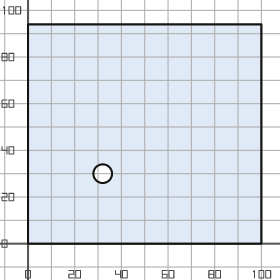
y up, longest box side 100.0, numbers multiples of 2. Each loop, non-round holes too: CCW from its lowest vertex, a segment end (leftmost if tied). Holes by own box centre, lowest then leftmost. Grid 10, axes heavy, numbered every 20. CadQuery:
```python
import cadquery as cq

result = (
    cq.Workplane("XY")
    .moveTo(0.0, 0.0)
    .lineTo(100.0, 0.0)
    .lineTo(100.0, 94.0)
    .lineTo(0.0, 94.0)
    .close()
    .moveTo(32.0, 30.0)
    .circle(4.0)
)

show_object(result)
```